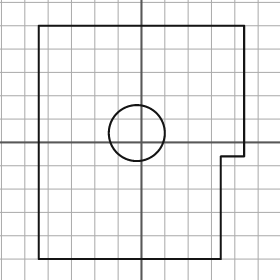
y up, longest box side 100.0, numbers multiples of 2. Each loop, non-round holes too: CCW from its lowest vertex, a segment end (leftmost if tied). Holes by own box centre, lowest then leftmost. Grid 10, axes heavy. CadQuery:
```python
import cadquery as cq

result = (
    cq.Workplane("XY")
    .moveTo(-44.0, -50.0)
    .lineTo(34.0, -50.0)
    .lineTo(34.0, -6.0)
    .lineTo(44.0, -6.0)
    .lineTo(44.0, 50.0)
    .lineTo(-44.0, 50.0)
    .close()
    .moveTo(-2.0, 4.0)
    .circle(12.0)
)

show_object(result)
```